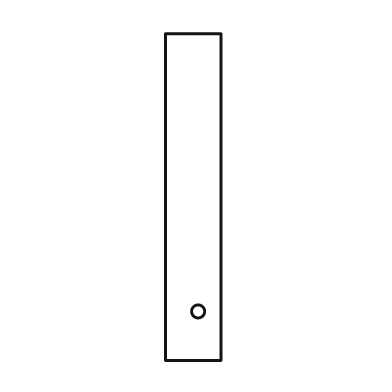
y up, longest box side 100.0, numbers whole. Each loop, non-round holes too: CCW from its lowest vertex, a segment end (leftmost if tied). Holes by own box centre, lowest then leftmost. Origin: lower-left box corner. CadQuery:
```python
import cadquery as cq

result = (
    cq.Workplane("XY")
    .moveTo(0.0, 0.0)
    .lineTo(17.0, 0.0)
    .lineTo(17.0, 100.0)
    .lineTo(0.0, 100.0)
    .close()
    .moveTo(10.0, 15.0)
    .circle(2.0)
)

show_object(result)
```